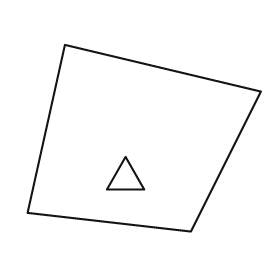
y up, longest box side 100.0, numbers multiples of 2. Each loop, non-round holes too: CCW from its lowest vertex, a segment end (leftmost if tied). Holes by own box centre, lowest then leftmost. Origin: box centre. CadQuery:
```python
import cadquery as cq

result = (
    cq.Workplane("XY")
    .moveTo(20.0, -40.0)
    .lineTo(50.0, 20.0)
    .lineTo(-34.0, 40.0)
    .lineTo(-50.0, -32.0)
    .close()
    .moveTo(-16.0, -22.0)
    .lineTo(0.0, -22.0)
    .lineTo(-8.0, -8.0)
    .close()
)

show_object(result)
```